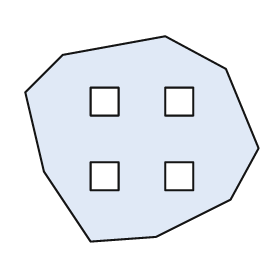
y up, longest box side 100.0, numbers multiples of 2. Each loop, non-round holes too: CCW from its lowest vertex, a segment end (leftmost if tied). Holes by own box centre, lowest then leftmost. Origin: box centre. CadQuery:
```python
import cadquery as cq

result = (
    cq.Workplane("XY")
    .moveTo(-22.0, -44.0)
    .lineTo(6.0, -42.0)
    .lineTo(38.0, -26.0)
    .lineTo(50.0, -4.0)
    .lineTo(36.0, 30.0)
    .lineTo(10.0, 44.0)
    .lineTo(-34.0, 36.0)
    .lineTo(-50.0, 20.0)
    .lineTo(-42.0, -14.0)
    .close()
    .moveTo(-22.0, -22.0)
    .lineTo(-10.0, -22.0)
    .lineTo(-10.0, -10.0)
    .lineTo(-22.0, -10.0)
    .close()
    .moveTo(10.0, -22.0)
    .lineTo(22.0, -22.0)
    .lineTo(22.0, -10.0)
    .lineTo(10.0, -10.0)
    .close()
    .moveTo(-22.0, 10.0)
    .lineTo(-10.0, 10.0)
    .lineTo(-10.0, 22.0)
    .lineTo(-22.0, 22.0)
    .close()
    .moveTo(10.0, 10.0)
    .lineTo(22.0, 10.0)
    .lineTo(22.0, 22.0)
    .lineTo(10.0, 22.0)
    .close()
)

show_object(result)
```